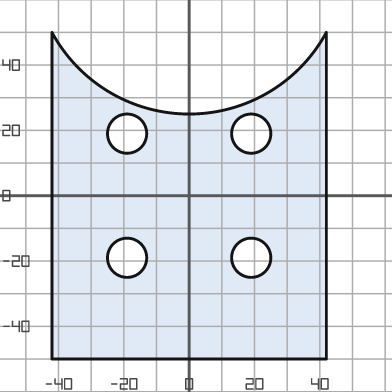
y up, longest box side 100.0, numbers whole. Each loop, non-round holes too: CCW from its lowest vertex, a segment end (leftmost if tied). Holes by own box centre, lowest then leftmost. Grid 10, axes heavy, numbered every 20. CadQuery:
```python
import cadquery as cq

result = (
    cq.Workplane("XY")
    .moveTo(-42.0, -50.0)
    .lineTo(42.0, -50.0)
    .lineTo(42.0, 50.0)
    .threePointArc((0.0, 25.0), (-42.0, 50.0))
    .close()
    .moveTo(-19.0, -19.0)
    .circle(6.0)
    .moveTo(19.0, -19.0)
    .circle(6.0)
    .moveTo(-19.0, 19.0)
    .circle(6.0)
    .moveTo(19.0, 19.0)
    .circle(6.0)
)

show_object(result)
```